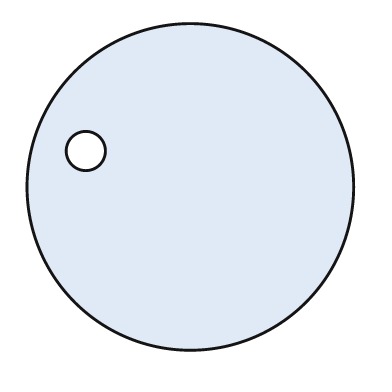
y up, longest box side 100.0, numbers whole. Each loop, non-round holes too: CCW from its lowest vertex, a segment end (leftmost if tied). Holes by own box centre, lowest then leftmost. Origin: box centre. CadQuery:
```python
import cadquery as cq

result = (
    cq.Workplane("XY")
    .moveTo(0.0, 0.0)
    .circle(50.0)
    .moveTo(-32.0, 11.0)
    .circle(6.0)
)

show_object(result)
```